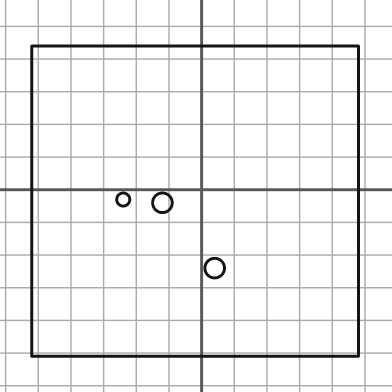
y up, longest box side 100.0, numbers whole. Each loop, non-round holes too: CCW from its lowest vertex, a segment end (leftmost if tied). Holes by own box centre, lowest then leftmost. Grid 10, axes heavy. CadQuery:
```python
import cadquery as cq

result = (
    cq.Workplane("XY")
    .moveTo(-52.0, -51.0)
    .lineTo(48.0, -51.0)
    .lineTo(48.0, 44.0)
    .lineTo(-52.0, 44.0)
    .close()
    .moveTo(4.0, -24.0)
    .circle(3.0)
    .moveTo(-12.0, -4.0)
    .circle(3.0)
    .moveTo(-24.0, -3.0)
    .circle(2.0)
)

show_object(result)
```